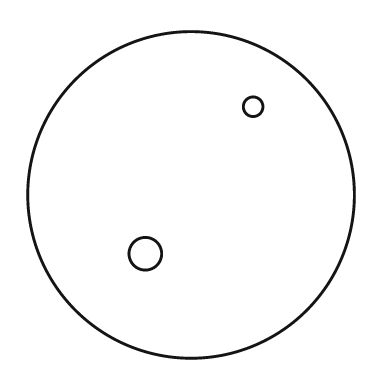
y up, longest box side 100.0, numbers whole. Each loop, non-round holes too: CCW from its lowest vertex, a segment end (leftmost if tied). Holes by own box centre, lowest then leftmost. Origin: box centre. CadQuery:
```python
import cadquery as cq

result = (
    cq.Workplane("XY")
    .moveTo(0.0, 0.0)
    .circle(50.0)
    .moveTo(-14.0, -18.0)
    .circle(5.0)
    .moveTo(19.0, 27.0)
    .circle(3.0)
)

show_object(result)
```